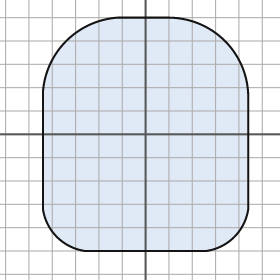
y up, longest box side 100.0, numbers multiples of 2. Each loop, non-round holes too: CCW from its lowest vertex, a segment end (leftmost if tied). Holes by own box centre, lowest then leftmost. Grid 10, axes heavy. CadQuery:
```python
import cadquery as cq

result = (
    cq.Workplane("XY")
    .moveTo(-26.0, -50.0)
    .lineTo(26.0, -50.0)
    .threePointArc((38.0, -44.0), (44.0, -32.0))
    .lineTo(44.0, 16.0)
    .threePointArc((34.0, 40.0), (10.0, 50.0))
    .lineTo(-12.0, 50.0)
    .threePointArc((-34.0, 40.0), (-44.0, 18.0))
    .lineTo(-44.0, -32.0)
    .threePointArc((-38.0, -44.0), (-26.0, -50.0))
    .close()
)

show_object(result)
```